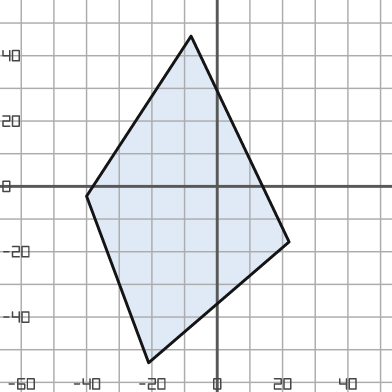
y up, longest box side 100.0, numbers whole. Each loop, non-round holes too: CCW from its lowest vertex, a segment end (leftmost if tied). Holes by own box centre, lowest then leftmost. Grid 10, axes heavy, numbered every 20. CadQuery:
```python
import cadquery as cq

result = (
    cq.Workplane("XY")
    .moveTo(-21.0, -54.0)
    .lineTo(22.0, -17.0)
    .lineTo(-8.0, 46.0)
    .lineTo(-40.0, -3.0)
    .close()
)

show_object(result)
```